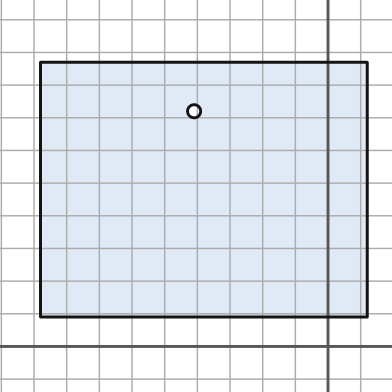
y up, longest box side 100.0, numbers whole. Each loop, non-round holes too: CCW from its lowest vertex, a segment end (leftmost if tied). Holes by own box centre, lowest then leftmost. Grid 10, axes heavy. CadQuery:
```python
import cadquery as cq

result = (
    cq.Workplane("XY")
    .moveTo(-88.0, 9.0)
    .lineTo(12.0, 9.0)
    .lineTo(12.0, 87.0)
    .lineTo(-88.0, 87.0)
    .close()
    .moveTo(-41.0, 72.0)
    .circle(2.0)
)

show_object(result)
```